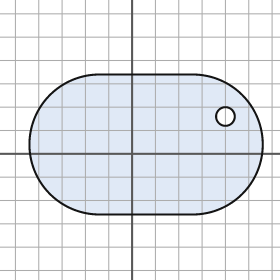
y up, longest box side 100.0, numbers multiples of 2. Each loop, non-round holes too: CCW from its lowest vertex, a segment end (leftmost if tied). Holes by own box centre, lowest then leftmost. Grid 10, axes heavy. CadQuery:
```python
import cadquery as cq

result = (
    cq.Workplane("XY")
    .moveTo(-14.0, -26.0)
    .lineTo(26.0, -26.0)
    .threePointArc((56.0, 4.0), (26.0, 34.0))
    .lineTo(-14.0, 34.0)
    .threePointArc((-44.0, 4.0), (-14.0, -26.0))
    .close()
    .moveTo(40.0, 16.0)
    .circle(4.0)
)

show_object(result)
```